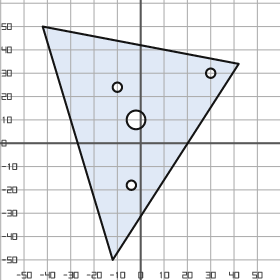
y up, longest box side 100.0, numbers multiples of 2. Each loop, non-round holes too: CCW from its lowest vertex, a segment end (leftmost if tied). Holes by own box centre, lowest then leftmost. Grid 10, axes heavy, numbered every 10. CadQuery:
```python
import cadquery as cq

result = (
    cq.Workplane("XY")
    .moveTo(-12.0, -50.0)
    .lineTo(42.0, 34.0)
    .lineTo(-42.0, 50.0)
    .close()
    .moveTo(-4.0, -18.0)
    .circle(2.0)
    .moveTo(-2.0, 10.0)
    .circle(4.0)
    .moveTo(-10.0, 24.0)
    .circle(2.0)
    .moveTo(30.0, 30.0)
    .circle(2.0)
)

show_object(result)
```